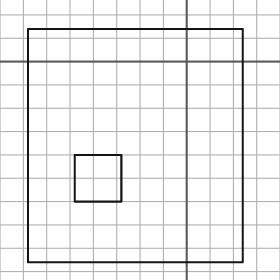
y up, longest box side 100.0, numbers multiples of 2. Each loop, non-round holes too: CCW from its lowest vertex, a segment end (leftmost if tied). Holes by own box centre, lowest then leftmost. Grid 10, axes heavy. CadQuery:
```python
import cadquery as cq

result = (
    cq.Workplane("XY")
    .moveTo(-68.0, -86.0)
    .lineTo(24.0, -86.0)
    .lineTo(24.0, 14.0)
    .lineTo(-68.0, 14.0)
    .close()
    .moveTo(-48.0, -60.0)
    .lineTo(-28.0, -60.0)
    .lineTo(-28.0, -40.0)
    .lineTo(-48.0, -40.0)
    .close()
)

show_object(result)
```